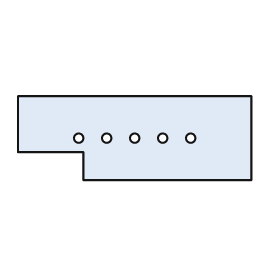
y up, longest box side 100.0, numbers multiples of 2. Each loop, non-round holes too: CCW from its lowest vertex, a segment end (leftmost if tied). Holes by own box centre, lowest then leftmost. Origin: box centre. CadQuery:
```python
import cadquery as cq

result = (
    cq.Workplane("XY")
    .moveTo(-22.0, -18.0)
    .lineTo(50.0, -18.0)
    .lineTo(50.0, 18.0)
    .lineTo(-50.0, 18.0)
    .lineTo(-50.0, -6.0)
    .lineTo(-22.0, -6.0)
    .close()
    .moveTo(-24.0, 0.0)
    .circle(2.0)
    .moveTo(-12.0, 0.0)
    .circle(2.0)
    .moveTo(0.0, 0.0)
    .circle(2.0)
    .moveTo(12.0, 0.0)
    .circle(2.0)
    .moveTo(24.0, 0.0)
    .circle(2.0)
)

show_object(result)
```